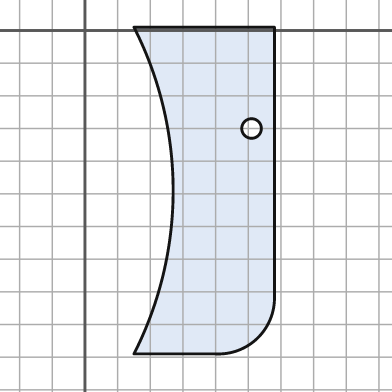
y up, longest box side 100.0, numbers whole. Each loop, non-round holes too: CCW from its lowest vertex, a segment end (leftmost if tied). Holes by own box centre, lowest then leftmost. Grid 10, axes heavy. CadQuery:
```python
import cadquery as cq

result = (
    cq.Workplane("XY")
    .moveTo(15.0, -99.0)
    .lineTo(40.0, -99.0)
    .threePointArc((53.0, -94.0), (58.0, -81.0))
    .lineTo(58.0, 1.0)
    .lineTo(15.0, 1.0)
    .threePointArc((27.0, -49.0), (15.0, -99.0))
    .close()
    .moveTo(51.0, -30.0)
    .circle(3.0)
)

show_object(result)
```